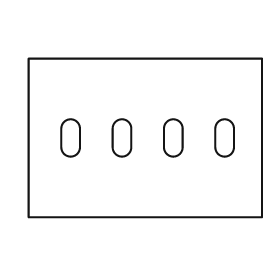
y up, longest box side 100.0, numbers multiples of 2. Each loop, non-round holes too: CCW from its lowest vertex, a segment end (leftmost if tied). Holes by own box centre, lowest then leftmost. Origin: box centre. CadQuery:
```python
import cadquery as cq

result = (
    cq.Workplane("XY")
    .moveTo(-50.0, -34.0)
    .lineTo(50.0, -34.0)
    .lineTo(50.0, 34.0)
    .lineTo(-50.0, 34.0)
    .close()
    .moveTo(-36.0, -4.0)
    .threePointArc((-32.0, -8.0), (-28.0, -4.0))
    .lineTo(-28.0, 4.0)
    .threePointArc((-32.0, 8.0), (-36.0, 4.0))
    .close()
    .moveTo(-14.0, -4.0)
    .threePointArc((-10.0, -8.0), (-6.0, -4.0))
    .lineTo(-6.0, 4.0)
    .threePointArc((-10.0, 8.0), (-14.0, 4.0))
    .close()
    .moveTo(8.0, -4.0)
    .threePointArc((12.0, -8.0), (16.0, -4.0))
    .lineTo(16.0, 4.0)
    .threePointArc((12.0, 8.0), (8.0, 4.0))
    .close()
    .moveTo(30.0, -4.0)
    .threePointArc((34.0, -8.0), (38.0, -4.0))
    .lineTo(38.0, 4.0)
    .threePointArc((34.0, 8.0), (30.0, 4.0))
    .close()
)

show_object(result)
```